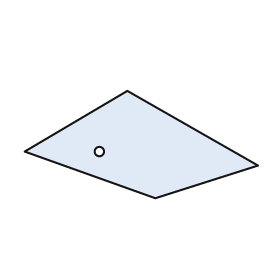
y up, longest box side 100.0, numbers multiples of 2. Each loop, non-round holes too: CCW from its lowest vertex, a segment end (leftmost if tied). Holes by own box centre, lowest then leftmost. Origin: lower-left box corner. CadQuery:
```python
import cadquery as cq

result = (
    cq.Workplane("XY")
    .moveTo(56.0, 0.0)
    .lineTo(100.0, 14.0)
    .lineTo(44.0, 46.0)
    .lineTo(0.0, 20.0)
    .close()
    .moveTo(32.0, 20.0)
    .circle(2.0)
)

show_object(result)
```